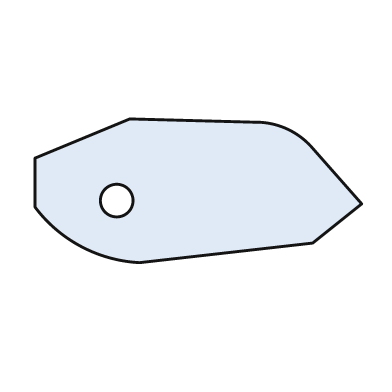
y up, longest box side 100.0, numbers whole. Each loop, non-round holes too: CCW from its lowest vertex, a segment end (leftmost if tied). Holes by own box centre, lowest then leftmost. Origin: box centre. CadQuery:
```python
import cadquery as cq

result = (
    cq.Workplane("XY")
    .moveTo(-18.0, -22.0)
    .lineTo(35.0, -16.0)
    .lineTo(50.0, -4.0)
    .lineTo(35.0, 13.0)
    .threePointArc((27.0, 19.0), (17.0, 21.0))
    .lineTo(-21.0, 22.0)
    .lineTo(-50.0, 10.0)
    .lineTo(-50.0, -5.0)
    .threePointArc((-36.0, -17.0), (-18.0, -22.0))
    .close()
    .moveTo(-25.0, -3.0)
    .circle(5.0)
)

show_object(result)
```